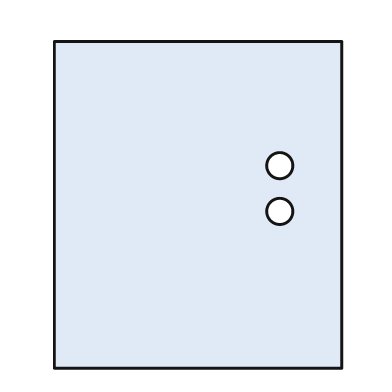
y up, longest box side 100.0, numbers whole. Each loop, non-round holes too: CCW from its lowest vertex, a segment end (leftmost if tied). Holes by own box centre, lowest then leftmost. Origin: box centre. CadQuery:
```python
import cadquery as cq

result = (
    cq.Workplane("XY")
    .moveTo(-44.0, -50.0)
    .lineTo(44.0, -50.0)
    .lineTo(44.0, 50.0)
    .lineTo(-44.0, 50.0)
    .close()
    .moveTo(25.0, -2.0)
    .circle(4.0)
    .moveTo(25.0, 12.0)
    .circle(4.0)
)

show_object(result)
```